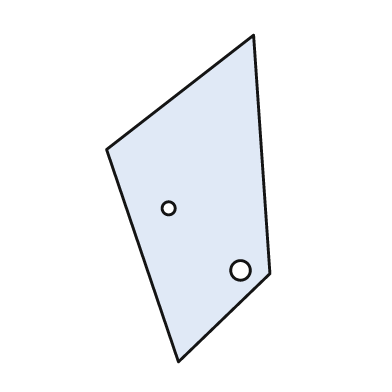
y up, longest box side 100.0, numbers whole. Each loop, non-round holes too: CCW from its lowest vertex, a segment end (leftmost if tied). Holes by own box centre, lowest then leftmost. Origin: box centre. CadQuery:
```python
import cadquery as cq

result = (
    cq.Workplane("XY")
    .moveTo(-3.0, -50.0)
    .lineTo(25.0, -23.0)
    .lineTo(20.0, 50.0)
    .lineTo(-25.0, 15.0)
    .close()
    .moveTo(16.0, -22.0)
    .circle(3.0)
    .moveTo(-6.0, -3.0)
    .circle(2.0)
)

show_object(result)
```